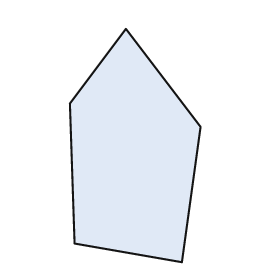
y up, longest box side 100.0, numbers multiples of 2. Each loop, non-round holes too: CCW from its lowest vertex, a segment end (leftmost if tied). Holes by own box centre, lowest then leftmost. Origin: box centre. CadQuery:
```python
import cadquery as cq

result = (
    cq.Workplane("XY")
    .moveTo(20.0, -50.0)
    .lineTo(28.0, 8.0)
    .lineTo(-4.0, 50.0)
    .lineTo(-28.0, 18.0)
    .lineTo(-26.0, -42.0)
    .close()
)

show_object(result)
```